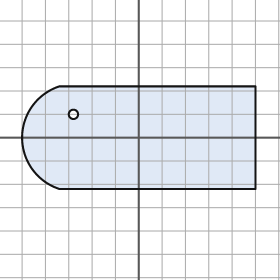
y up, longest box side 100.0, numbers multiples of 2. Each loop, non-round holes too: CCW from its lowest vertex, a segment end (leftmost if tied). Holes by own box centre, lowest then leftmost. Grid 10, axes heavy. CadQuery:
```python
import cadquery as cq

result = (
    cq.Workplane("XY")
    .moveTo(-34.0, -22.0)
    .lineTo(50.0, -22.0)
    .lineTo(50.0, 22.0)
    .lineTo(-34.0, 22.0)
    .threePointArc((-50.0, 0.0), (-34.0, -22.0))
    .close()
    .moveTo(-28.0, 10.0)
    .circle(2.0)
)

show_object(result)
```